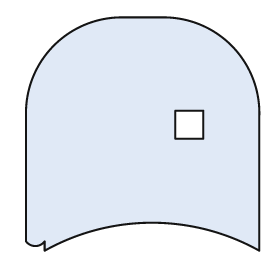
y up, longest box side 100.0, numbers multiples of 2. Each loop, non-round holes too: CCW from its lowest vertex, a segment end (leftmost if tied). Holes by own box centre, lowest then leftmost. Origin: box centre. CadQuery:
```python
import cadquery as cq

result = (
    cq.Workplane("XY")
    .moveTo(-42.0, -50.0)
    .threePointArc((4.0, -38.0), (50.0, -50.0))
    .lineTo(50.0, 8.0)
    .threePointArc((38.0, 38.0), (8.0, 50.0))
    .lineTo(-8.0, 50.0)
    .threePointArc((-38.0, 38.0), (-50.0, 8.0))
    .lineTo(-50.0, -46.0)
    .threePointArc((-46.0, -48.0), (-42.0, -46.0))
    .close()
    .moveTo(14.0, -2.0)
    .lineTo(26.0, -2.0)
    .lineTo(26.0, 10.0)
    .lineTo(14.0, 10.0)
    .close()
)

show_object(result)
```